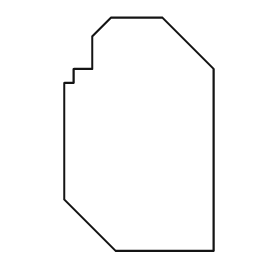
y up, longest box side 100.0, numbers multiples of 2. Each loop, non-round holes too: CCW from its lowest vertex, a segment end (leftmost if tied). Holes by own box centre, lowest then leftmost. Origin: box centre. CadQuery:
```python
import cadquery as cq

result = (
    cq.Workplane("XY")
    .moveTo(-10.0, -50.0)
    .lineTo(32.0, -50.0)
    .lineTo(32.0, 28.0)
    .lineTo(10.0, 50.0)
    .lineTo(-12.0, 50.0)
    .lineTo(-20.0, 42.0)
    .lineTo(-20.0, 28.0)
    .lineTo(-28.0, 28.0)
    .lineTo(-28.0, 22.0)
    .lineTo(-32.0, 22.0)
    .lineTo(-32.0, -28.0)
    .close()
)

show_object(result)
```